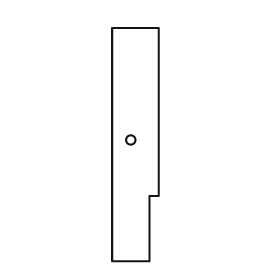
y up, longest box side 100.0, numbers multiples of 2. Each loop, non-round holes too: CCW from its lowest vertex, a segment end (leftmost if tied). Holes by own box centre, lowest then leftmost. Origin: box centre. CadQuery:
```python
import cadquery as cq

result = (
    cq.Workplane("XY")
    .moveTo(-10.0, -50.0)
    .lineTo(6.0, -50.0)
    .lineTo(6.0, -22.0)
    .lineTo(10.0, -22.0)
    .lineTo(10.0, 50.0)
    .lineTo(-10.0, 50.0)
    .close()
    .moveTo(-2.0, 2.0)
    .circle(2.0)
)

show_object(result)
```